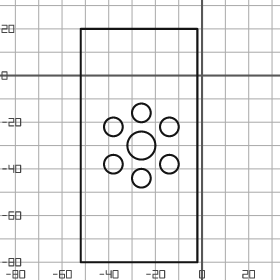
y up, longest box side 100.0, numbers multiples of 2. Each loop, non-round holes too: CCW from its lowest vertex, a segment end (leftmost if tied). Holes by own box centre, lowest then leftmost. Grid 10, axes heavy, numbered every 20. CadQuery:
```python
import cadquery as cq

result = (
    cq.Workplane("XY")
    .moveTo(-52.0, -80.0)
    .lineTo(-2.0, -80.0)
    .lineTo(-2.0, 20.0)
    .lineTo(-52.0, 20.0)
    .close()
    .moveTo(-26.0, -44.0)
    .circle(4.0)
    .moveTo(-38.0, -38.0)
    .circle(4.0)
    .moveTo(-14.0, -38.0)
    .circle(4.0)
    .moveTo(-26.0, -30.0)
    .circle(6.0)
    .moveTo(-38.0, -22.0)
    .circle(4.0)
    .moveTo(-14.0, -22.0)
    .circle(4.0)
    .moveTo(-26.0, -16.0)
    .circle(4.0)
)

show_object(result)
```